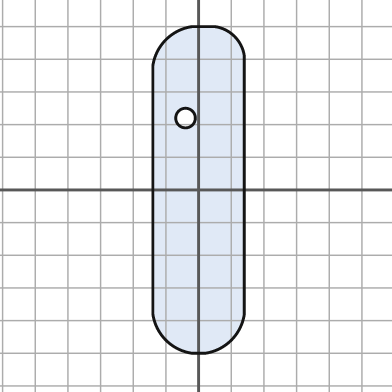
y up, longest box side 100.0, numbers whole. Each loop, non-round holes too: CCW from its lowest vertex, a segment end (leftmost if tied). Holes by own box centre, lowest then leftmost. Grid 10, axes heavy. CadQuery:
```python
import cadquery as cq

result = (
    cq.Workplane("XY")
    .moveTo(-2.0, -50.0)
    .lineTo(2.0, -50.0)
    .threePointArc((10.0, -46.0), (14.0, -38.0))
    .lineTo(14.0, 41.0)
    .threePointArc((11.0, 47.0), (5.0, 50.0))
    .lineTo(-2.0, 50.0)
    .threePointArc((-10.0, 46.0), (-14.0, 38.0))
    .lineTo(-14.0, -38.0)
    .threePointArc((-10.0, -46.0), (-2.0, -50.0))
    .close()
    .moveTo(-4.0, 22.0)
    .circle(3.0)
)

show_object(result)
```